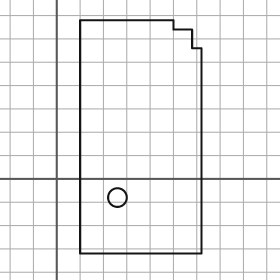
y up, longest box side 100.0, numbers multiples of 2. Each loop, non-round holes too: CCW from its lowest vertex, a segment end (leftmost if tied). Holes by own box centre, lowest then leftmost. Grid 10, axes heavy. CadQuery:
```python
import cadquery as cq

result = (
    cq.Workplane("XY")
    .moveTo(10.0, -32.0)
    .lineTo(62.0, -32.0)
    .lineTo(62.0, 56.0)
    .lineTo(58.0, 56.0)
    .lineTo(58.0, 64.0)
    .lineTo(50.0, 64.0)
    .lineTo(50.0, 68.0)
    .lineTo(10.0, 68.0)
    .close()
    .moveTo(26.0, -8.0)
    .circle(4.0)
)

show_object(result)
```